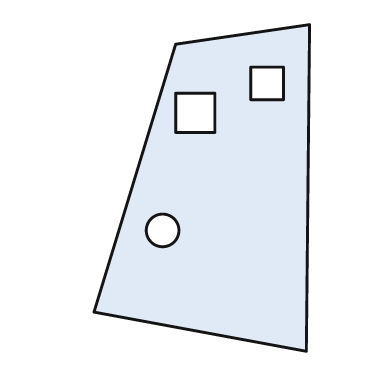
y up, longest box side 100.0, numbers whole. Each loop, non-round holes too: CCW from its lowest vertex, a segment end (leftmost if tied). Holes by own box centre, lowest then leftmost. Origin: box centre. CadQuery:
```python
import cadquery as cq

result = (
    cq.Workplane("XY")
    .moveTo(32.0, -50.0)
    .lineTo(33.0, 50.0)
    .lineTo(-8.0, 44.0)
    .lineTo(-33.0, -38.0)
    .close()
    .moveTo(-12.0, -13.0)
    .circle(5.0)
    .moveTo(-8.0, 17.0)
    .lineTo(4.0, 17.0)
    .lineTo(4.0, 29.0)
    .lineTo(-8.0, 29.0)
    .close()
    .moveTo(15.0, 27.0)
    .lineTo(25.0, 27.0)
    .lineTo(25.0, 37.0)
    .lineTo(15.0, 37.0)
    .close()
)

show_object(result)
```